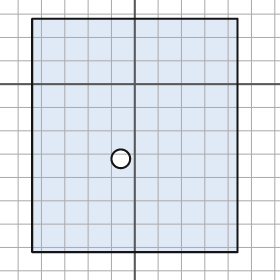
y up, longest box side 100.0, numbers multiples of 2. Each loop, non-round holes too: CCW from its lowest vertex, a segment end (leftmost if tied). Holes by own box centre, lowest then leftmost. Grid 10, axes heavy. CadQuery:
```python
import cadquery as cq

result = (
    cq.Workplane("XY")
    .moveTo(-44.0, -72.0)
    .lineTo(44.0, -72.0)
    .lineTo(44.0, 28.0)
    .lineTo(-44.0, 28.0)
    .close()
    .moveTo(-6.0, -32.0)
    .circle(4.0)
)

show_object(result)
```